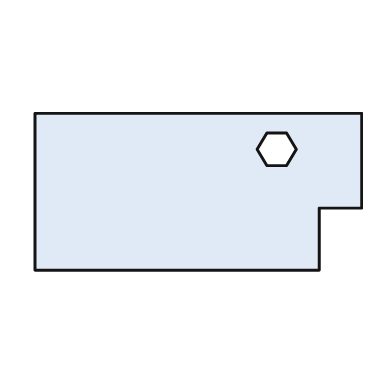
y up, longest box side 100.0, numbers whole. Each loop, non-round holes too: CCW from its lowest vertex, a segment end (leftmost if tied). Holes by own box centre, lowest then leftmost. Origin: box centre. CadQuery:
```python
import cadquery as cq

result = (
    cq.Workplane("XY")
    .moveTo(-50.0, -24.0)
    .lineTo(37.0, -24.0)
    .lineTo(37.0, -5.0)
    .lineTo(50.0, -5.0)
    .lineTo(50.0, 24.0)
    .lineTo(-50.0, 24.0)
    .close()
    .moveTo(21.0, 8.0)
    .lineTo(27.0, 8.0)
    .lineTo(30.0, 13.0)
    .lineTo(27.0, 18.0)
    .lineTo(21.0, 18.0)
    .lineTo(18.0, 13.0)
    .close()
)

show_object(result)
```